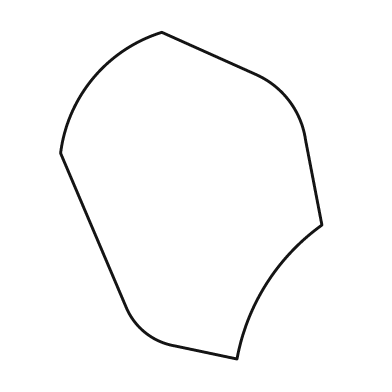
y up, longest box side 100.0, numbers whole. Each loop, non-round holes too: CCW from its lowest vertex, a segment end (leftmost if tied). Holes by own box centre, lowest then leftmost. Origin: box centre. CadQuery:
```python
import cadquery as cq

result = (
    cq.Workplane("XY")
    .moveTo(14.0, -50.0)
    .threePointArc((23.0, -27.0), (40.0, -9.0))
    .lineTo(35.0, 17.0)
    .threePointArc((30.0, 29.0), (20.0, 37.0))
    .lineTo(-9.0, 50.0)
    .threePointArc((-30.0, 36.0), (-40.0, 13.0))
    .lineTo(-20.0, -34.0)
    .threePointArc((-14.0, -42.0), (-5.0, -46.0))
    .close()
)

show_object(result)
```